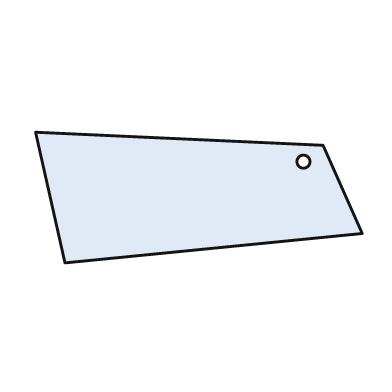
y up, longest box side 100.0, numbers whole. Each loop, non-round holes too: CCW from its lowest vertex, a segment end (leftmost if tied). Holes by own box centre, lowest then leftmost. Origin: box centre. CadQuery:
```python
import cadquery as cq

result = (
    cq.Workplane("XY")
    .moveTo(-41.0, -20.0)
    .lineTo(50.0, -11.0)
    .lineTo(38.0, 16.0)
    .lineTo(-50.0, 20.0)
    .close()
    .moveTo(32.0, 11.0)
    .circle(2.0)
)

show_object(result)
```